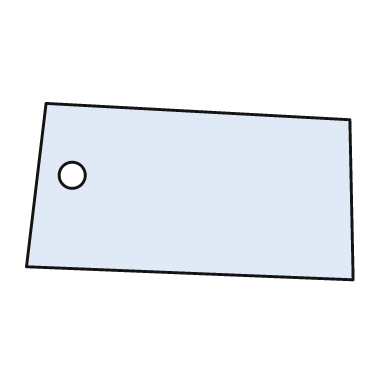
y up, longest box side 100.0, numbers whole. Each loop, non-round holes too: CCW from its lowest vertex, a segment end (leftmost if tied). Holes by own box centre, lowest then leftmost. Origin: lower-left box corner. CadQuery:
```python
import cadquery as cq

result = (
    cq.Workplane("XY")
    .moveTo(100.0, 0.0)
    .lineTo(99.0, 49.0)
    .lineTo(6.0, 54.0)
    .lineTo(0.0, 4.0)
    .close()
    .moveTo(14.0, 32.0)
    .circle(4.0)
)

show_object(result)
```